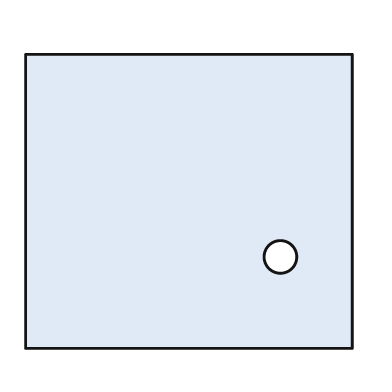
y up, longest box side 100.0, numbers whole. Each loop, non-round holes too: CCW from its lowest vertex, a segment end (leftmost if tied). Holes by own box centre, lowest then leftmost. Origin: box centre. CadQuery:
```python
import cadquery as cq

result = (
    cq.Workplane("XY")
    .moveTo(-50.0, -45.0)
    .lineTo(50.0, -45.0)
    .lineTo(50.0, 45.0)
    .lineTo(-50.0, 45.0)
    .close()
    .moveTo(28.0, -17.0)
    .circle(5.0)
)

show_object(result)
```